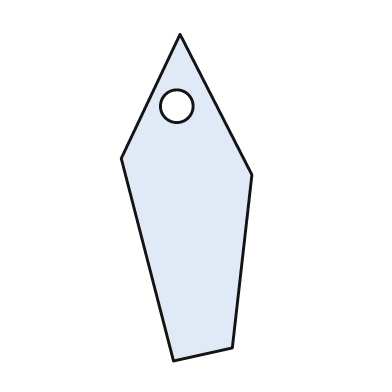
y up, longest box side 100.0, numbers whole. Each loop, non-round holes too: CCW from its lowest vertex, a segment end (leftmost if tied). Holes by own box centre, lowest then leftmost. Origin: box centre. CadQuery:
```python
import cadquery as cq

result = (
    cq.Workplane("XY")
    .moveTo(-4.0, -50.0)
    .lineTo(14.0, -46.0)
    .lineTo(20.0, 7.0)
    .lineTo(-2.0, 50.0)
    .lineTo(-20.0, 12.0)
    .close()
    .moveTo(-3.0, 28.0)
    .circle(5.0)
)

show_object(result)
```